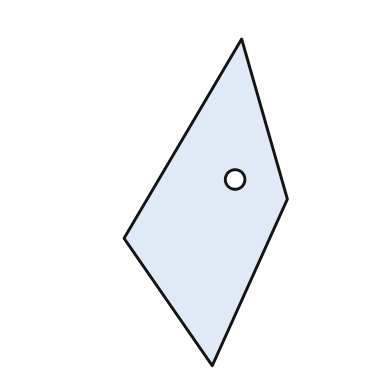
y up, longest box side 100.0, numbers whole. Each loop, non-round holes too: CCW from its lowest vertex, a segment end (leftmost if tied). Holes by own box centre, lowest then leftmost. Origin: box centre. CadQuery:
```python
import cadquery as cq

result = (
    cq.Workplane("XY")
    .moveTo(2.0, -50.0)
    .lineTo(25.0, 1.0)
    .lineTo(11.0, 50.0)
    .lineTo(-25.0, -11.0)
    .close()
    .moveTo(9.0, 7.0)
    .circle(3.0)
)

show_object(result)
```